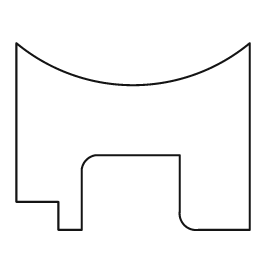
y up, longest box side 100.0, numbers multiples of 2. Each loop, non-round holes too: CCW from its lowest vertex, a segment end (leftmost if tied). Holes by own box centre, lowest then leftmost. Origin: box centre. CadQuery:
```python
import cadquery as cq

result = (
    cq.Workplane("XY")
    .moveTo(-32.0, -40.0)
    .lineTo(-22.0, -40.0)
    .lineTo(-22.0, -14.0)
    .threePointArc((-20.0, -10.0), (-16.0, -8.0))
    .lineTo(20.0, -8.0)
    .lineTo(20.0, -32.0)
    .threePointArc((22.0, -38.0), (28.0, -40.0))
    .lineTo(50.0, -40.0)
    .lineTo(50.0, 40.0)
    .threePointArc((0.0, 22.0), (-50.0, 40.0))
    .lineTo(-50.0, -28.0)
    .lineTo(-32.0, -28.0)
    .close()
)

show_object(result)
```